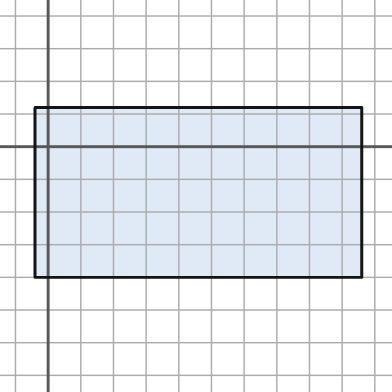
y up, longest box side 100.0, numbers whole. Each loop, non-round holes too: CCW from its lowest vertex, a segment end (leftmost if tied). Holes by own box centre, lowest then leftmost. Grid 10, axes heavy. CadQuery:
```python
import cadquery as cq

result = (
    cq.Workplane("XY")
    .moveTo(-4.0, -40.0)
    .lineTo(96.0, -40.0)
    .lineTo(96.0, 12.0)
    .lineTo(-4.0, 12.0)
    .close()
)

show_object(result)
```